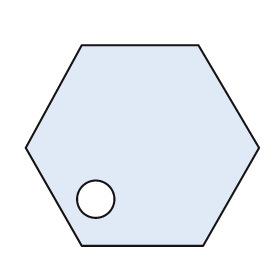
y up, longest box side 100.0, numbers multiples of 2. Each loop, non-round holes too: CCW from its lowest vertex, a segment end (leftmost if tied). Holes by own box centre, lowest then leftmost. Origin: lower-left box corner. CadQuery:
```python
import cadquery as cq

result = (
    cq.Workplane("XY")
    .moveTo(24.0, 0.0)
    .lineTo(76.0, 0.0)
    .lineTo(100.0, 42.0)
    .lineTo(74.0, 86.0)
    .lineTo(24.0, 86.0)
    .lineTo(0.0, 42.0)
    .close()
    .moveTo(30.0, 20.0)
    .circle(8.0)
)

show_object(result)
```